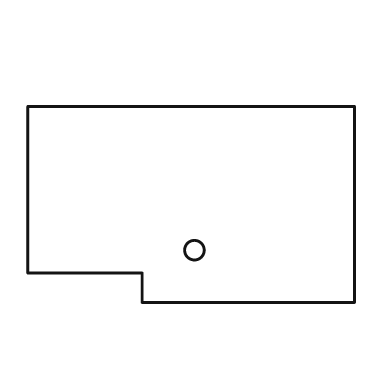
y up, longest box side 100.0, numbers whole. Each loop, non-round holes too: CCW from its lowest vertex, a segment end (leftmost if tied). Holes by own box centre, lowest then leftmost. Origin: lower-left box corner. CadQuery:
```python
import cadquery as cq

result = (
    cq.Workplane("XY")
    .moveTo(35.0, 0.0)
    .lineTo(100.0, 0.0)
    .lineTo(100.0, 60.0)
    .lineTo(0.0, 60.0)
    .lineTo(0.0, 9.0)
    .lineTo(35.0, 9.0)
    .close()
    .moveTo(51.0, 16.0)
    .circle(3.0)
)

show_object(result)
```